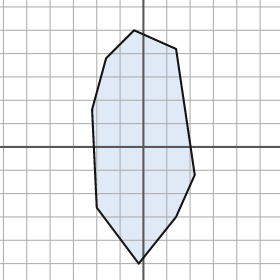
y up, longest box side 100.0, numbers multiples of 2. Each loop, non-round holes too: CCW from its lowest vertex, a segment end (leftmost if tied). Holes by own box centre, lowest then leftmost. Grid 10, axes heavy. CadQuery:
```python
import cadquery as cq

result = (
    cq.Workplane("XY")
    .moveTo(-2.0, -50.0)
    .lineTo(14.0, -30.0)
    .lineTo(22.0, -12.0)
    .lineTo(14.0, 42.0)
    .lineTo(-4.0, 50.0)
    .lineTo(-16.0, 38.0)
    .lineTo(-22.0, 16.0)
    .lineTo(-20.0, -26.0)
    .close()
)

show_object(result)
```